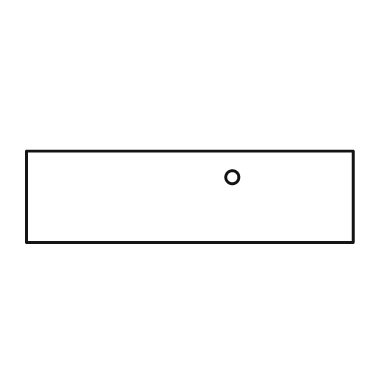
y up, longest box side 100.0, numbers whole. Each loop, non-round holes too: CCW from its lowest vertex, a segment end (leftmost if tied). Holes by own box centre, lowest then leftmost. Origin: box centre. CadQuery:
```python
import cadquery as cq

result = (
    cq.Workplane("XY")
    .moveTo(-50.0, -14.0)
    .lineTo(50.0, -14.0)
    .lineTo(50.0, 14.0)
    .lineTo(-50.0, 14.0)
    .close()
    .moveTo(13.0, 6.0)
    .circle(2.0)
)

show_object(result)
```